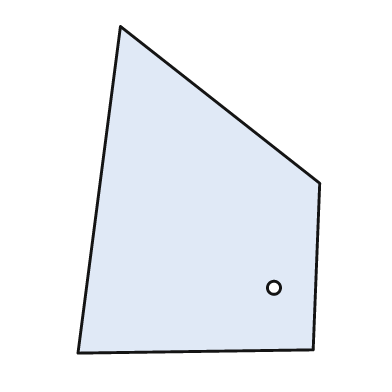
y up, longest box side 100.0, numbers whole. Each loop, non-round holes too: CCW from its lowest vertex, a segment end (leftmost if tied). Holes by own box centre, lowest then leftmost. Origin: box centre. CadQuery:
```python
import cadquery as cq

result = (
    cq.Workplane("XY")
    .moveTo(-37.0, -50.0)
    .lineTo(35.0, -49.0)
    .lineTo(37.0, 2.0)
    .lineTo(-24.0, 50.0)
    .close()
    .moveTo(23.0, -30.0)
    .circle(2.0)
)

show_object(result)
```